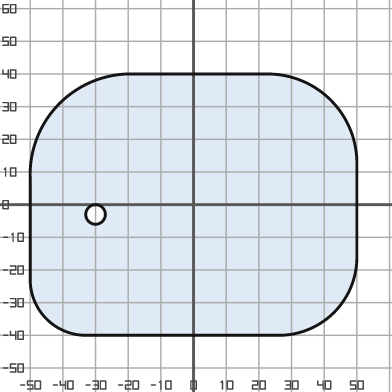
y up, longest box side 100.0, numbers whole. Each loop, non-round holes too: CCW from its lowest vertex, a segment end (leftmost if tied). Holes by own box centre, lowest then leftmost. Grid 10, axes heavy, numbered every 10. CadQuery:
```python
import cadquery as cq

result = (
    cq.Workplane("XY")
    .moveTo(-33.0, -40.0)
    .lineTo(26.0, -40.0)
    .threePointArc((43.0, -33.0), (50.0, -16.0))
    .lineTo(50.0, 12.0)
    .threePointArc((42.0, 32.0), (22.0, 40.0))
    .lineTo(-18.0, 40.0)
    .threePointArc((-41.0, 31.0), (-50.0, 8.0))
    .lineTo(-50.0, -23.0)
    .threePointArc((-45.0, -35.0), (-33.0, -40.0))
    .close()
    .moveTo(-30.0, -3.0)
    .circle(3.0)
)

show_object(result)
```